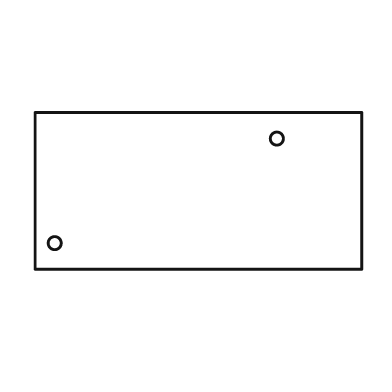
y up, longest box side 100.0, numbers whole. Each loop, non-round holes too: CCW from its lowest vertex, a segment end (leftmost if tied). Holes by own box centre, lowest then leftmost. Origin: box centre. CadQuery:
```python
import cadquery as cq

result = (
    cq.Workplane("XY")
    .moveTo(-50.0, -24.0)
    .lineTo(50.0, -24.0)
    .lineTo(50.0, 24.0)
    .lineTo(-50.0, 24.0)
    .close()
    .moveTo(-44.0, -16.0)
    .circle(2.0)
    .moveTo(24.0, 16.0)
    .circle(2.0)
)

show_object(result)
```